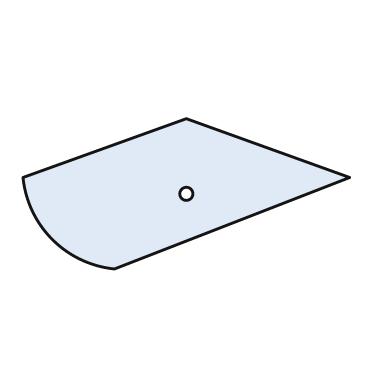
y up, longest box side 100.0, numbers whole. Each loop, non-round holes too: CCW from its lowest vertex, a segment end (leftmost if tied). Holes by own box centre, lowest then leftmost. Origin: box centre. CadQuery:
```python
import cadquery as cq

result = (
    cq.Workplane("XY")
    .moveTo(-22.0, -23.0)
    .lineTo(50.0, 5.0)
    .lineTo(0.0, 23.0)
    .lineTo(-50.0, 5.0)
    .threePointArc((-41.0, -14.0), (-22.0, -23.0))
    .close()
    .moveTo(0.0, 0.0)
    .circle(2.0)
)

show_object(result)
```